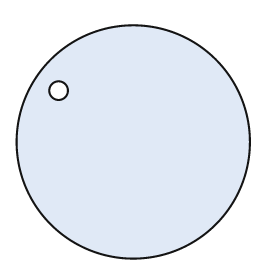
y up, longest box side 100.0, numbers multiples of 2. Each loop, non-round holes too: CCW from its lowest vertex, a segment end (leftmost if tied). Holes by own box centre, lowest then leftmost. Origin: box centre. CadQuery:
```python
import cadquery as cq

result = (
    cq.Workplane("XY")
    .moveTo(0.0, 0.0)
    .circle(50.0)
    .moveTo(-32.0, 22.0)
    .circle(4.0)
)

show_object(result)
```